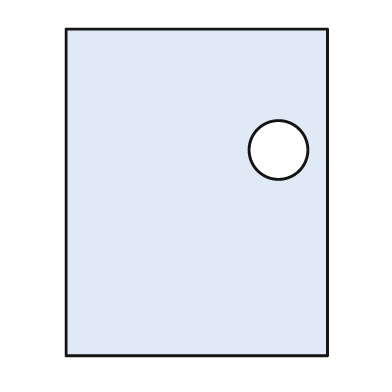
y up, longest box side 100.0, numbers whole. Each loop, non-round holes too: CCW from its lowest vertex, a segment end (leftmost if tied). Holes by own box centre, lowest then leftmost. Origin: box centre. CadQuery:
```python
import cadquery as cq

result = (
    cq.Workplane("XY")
    .moveTo(-40.0, -50.0)
    .lineTo(40.0, -50.0)
    .lineTo(40.0, 50.0)
    .lineTo(-40.0, 50.0)
    .close()
    .moveTo(25.0, 13.0)
    .circle(9.0)
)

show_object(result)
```